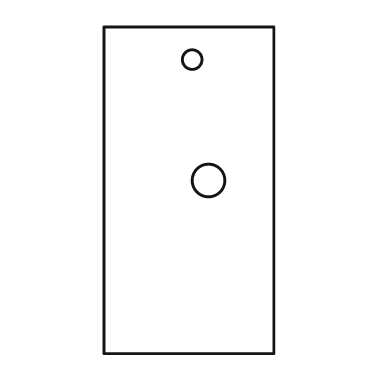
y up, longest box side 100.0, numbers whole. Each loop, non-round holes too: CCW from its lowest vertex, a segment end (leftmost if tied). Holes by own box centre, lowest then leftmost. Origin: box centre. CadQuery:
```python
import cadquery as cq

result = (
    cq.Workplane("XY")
    .moveTo(-26.0, -50.0)
    .lineTo(26.0, -50.0)
    .lineTo(26.0, 50.0)
    .lineTo(-26.0, 50.0)
    .close()
    .moveTo(6.0, 3.0)
    .circle(5.0)
    .moveTo(1.0, 40.0)
    .circle(3.0)
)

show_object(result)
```